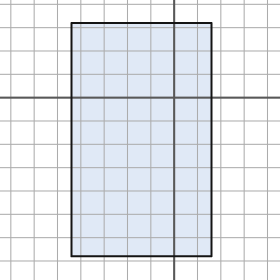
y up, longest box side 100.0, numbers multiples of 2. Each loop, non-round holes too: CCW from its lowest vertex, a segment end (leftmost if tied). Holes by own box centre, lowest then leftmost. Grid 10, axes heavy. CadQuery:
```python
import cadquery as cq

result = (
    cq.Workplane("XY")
    .moveTo(-44.0, -68.0)
    .lineTo(16.0, -68.0)
    .lineTo(16.0, 32.0)
    .lineTo(-44.0, 32.0)
    .close()
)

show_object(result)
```